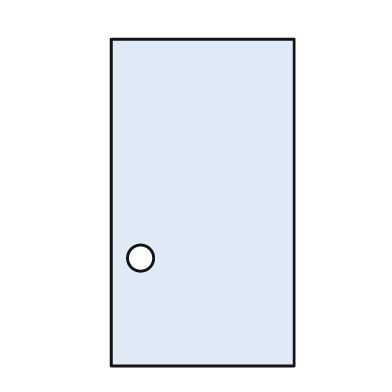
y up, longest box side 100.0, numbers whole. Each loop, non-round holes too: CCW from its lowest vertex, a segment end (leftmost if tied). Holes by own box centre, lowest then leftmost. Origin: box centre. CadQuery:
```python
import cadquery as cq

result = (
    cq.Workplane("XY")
    .moveTo(-28.0, -50.0)
    .lineTo(28.0, -50.0)
    .lineTo(28.0, 50.0)
    .lineTo(-28.0, 50.0)
    .close()
    .moveTo(-19.0, -17.0)
    .circle(4.0)
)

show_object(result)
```